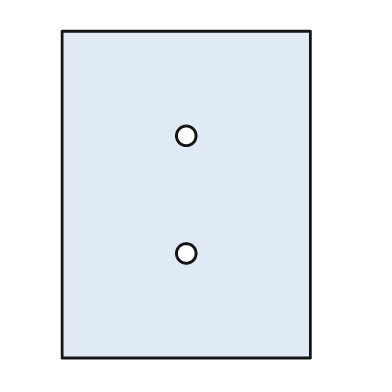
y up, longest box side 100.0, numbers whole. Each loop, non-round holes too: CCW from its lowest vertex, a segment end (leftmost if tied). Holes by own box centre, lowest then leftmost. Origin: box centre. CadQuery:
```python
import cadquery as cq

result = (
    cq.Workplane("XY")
    .moveTo(-38.0, -50.0)
    .lineTo(38.0, -50.0)
    .lineTo(38.0, 50.0)
    .lineTo(-38.0, 50.0)
    .close()
    .moveTo(0.0, -18.0)
    .circle(3.0)
    .moveTo(0.0, 18.0)
    .circle(3.0)
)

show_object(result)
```